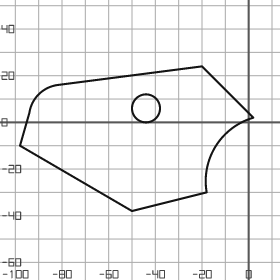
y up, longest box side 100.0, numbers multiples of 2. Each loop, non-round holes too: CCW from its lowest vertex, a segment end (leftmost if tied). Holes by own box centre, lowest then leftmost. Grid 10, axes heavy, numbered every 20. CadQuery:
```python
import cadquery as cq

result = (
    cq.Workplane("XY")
    .moveTo(-50.0, -38.0)
    .lineTo(-18.0, -30.0)
    .threePointArc((-14.0, -10.0), (2.0, 2.0))
    .lineTo(-20.0, 24.0)
    .lineTo(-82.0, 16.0)
    .threePointArc((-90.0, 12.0), (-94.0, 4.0))
    .lineTo(-98.0, -10.0)
    .close()
    .moveTo(-44.0, 6.0)
    .circle(6.0)
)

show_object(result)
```